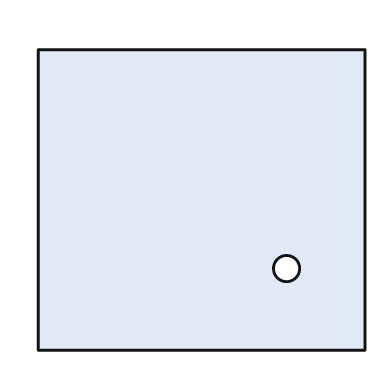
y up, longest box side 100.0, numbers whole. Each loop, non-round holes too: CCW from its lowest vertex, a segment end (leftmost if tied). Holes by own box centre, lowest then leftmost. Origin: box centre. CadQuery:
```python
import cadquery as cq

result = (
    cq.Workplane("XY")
    .moveTo(-50.0, -46.0)
    .lineTo(50.0, -46.0)
    .lineTo(50.0, 46.0)
    .lineTo(-50.0, 46.0)
    .close()
    .moveTo(26.0, -21.0)
    .circle(4.0)
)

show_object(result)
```